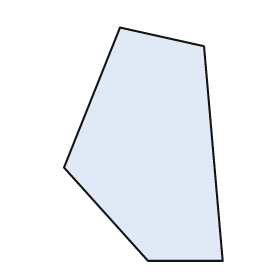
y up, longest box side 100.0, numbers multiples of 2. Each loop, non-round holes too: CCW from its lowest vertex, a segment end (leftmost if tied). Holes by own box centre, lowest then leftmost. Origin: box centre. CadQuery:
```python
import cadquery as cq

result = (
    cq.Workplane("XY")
    .moveTo(2.0, -50.0)
    .lineTo(34.0, -50.0)
    .lineTo(26.0, 42.0)
    .lineTo(-10.0, 50.0)
    .lineTo(-34.0, -10.0)
    .close()
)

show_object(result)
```